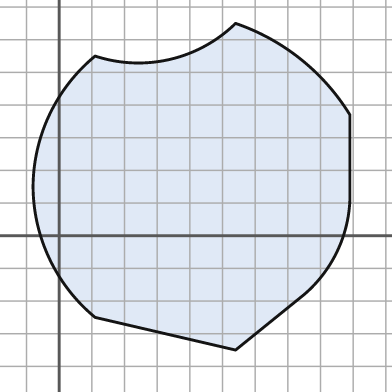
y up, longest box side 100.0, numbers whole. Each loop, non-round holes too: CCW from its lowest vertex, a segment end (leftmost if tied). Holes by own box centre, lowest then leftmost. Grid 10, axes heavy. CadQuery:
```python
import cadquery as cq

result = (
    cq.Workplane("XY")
    .moveTo(54.0, -35.0)
    .lineTo(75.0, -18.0)
    .threePointArc((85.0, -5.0), (89.0, 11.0))
    .lineTo(89.0, 37.0)
    .threePointArc((74.0, 54.0), (54.0, 65.0))
    .threePointArc((34.0, 54.0), (11.0, 55.0))
    .threePointArc((-3.0, 37.0), (-8.0, 15.0))
    .threePointArc((-3.0, -7.0), (11.0, -25.0))
    .close()
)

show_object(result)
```